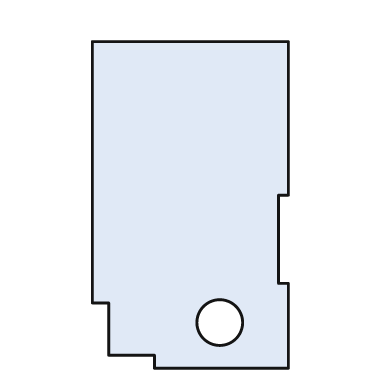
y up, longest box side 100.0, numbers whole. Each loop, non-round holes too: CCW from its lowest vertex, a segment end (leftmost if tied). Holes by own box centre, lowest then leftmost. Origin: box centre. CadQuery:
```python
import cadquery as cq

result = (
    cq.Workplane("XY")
    .moveTo(-11.0, -50.0)
    .lineTo(30.0, -50.0)
    .lineTo(30.0, -24.0)
    .lineTo(27.0, -24.0)
    .lineTo(27.0, 3.0)
    .lineTo(30.0, 3.0)
    .lineTo(30.0, 50.0)
    .lineTo(-30.0, 50.0)
    .lineTo(-30.0, -30.0)
    .lineTo(-25.0, -30.0)
    .lineTo(-25.0, -46.0)
    .lineTo(-11.0, -46.0)
    .close()
    .moveTo(9.0, -36.0)
    .circle(7.0)
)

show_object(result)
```